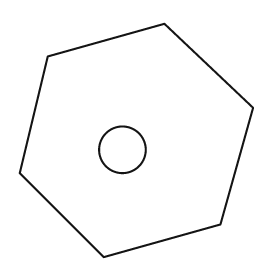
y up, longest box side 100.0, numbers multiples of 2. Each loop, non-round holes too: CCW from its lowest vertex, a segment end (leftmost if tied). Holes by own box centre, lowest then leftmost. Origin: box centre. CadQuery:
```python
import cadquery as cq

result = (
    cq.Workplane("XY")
    .moveTo(-14.0, -50.0)
    .lineTo(36.0, -36.0)
    .lineTo(50.0, 14.0)
    .lineTo(12.0, 50.0)
    .lineTo(-38.0, 36.0)
    .lineTo(-50.0, -14.0)
    .close()
    .moveTo(-6.0, -4.0)
    .circle(10.0)
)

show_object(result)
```